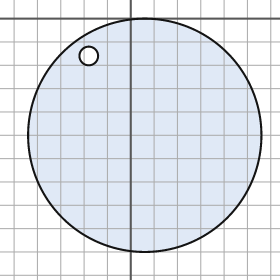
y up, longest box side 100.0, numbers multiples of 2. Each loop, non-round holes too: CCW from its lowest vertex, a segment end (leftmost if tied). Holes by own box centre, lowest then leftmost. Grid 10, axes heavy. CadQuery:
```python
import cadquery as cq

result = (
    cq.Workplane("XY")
    .moveTo(6.0, -50.0)
    .circle(50.0)
    .moveTo(-18.0, -16.0)
    .circle(4.0)
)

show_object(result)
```